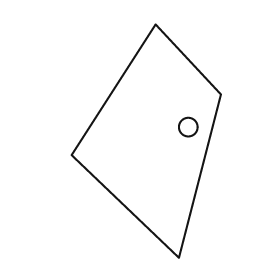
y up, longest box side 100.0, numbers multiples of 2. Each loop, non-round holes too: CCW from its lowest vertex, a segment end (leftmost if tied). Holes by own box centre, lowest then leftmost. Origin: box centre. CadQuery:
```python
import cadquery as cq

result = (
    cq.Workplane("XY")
    .moveTo(14.0, -50.0)
    .lineTo(32.0, 20.0)
    .lineTo(4.0, 50.0)
    .lineTo(-32.0, -6.0)
    .close()
    .moveTo(18.0, 6.0)
    .circle(4.0)
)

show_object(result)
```